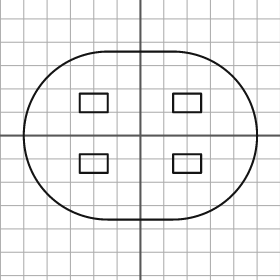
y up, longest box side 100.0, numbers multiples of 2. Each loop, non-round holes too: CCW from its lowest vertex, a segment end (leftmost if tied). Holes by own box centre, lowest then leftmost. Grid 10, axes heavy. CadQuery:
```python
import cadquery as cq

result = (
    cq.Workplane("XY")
    .moveTo(-14.0, -36.0)
    .lineTo(14.0, -36.0)
    .threePointArc((50.0, 0.0), (14.0, 36.0))
    .lineTo(-14.0, 36.0)
    .threePointArc((-50.0, 0.0), (-14.0, -36.0))
    .close()
    .moveTo(-26.0, -16.0)
    .lineTo(-14.0, -16.0)
    .lineTo(-14.0, -8.0)
    .lineTo(-26.0, -8.0)
    .close()
    .moveTo(14.0, -16.0)
    .lineTo(26.0, -16.0)
    .lineTo(26.0, -8.0)
    .lineTo(14.0, -8.0)
    .close()
    .moveTo(-26.0, 10.0)
    .lineTo(-14.0, 10.0)
    .lineTo(-14.0, 18.0)
    .lineTo(-26.0, 18.0)
    .close()
    .moveTo(14.0, 10.0)
    .lineTo(26.0, 10.0)
    .lineTo(26.0, 18.0)
    .lineTo(14.0, 18.0)
    .close()
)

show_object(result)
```